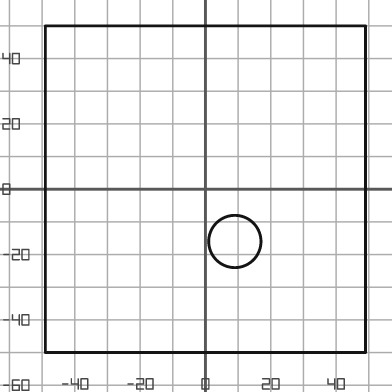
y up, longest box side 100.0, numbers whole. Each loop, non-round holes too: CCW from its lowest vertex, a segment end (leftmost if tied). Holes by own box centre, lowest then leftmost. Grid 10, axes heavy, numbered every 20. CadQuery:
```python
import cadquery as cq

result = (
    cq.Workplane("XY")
    .moveTo(-49.0, -50.0)
    .lineTo(49.0, -50.0)
    .lineTo(49.0, 50.0)
    .lineTo(-49.0, 50.0)
    .close()
    .moveTo(9.0, -16.0)
    .circle(8.0)
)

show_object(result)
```